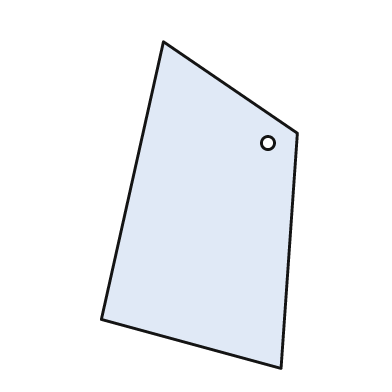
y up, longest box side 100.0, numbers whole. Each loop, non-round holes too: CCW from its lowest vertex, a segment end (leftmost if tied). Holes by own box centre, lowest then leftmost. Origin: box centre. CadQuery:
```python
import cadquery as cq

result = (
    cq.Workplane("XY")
    .moveTo(25.0, -50.0)
    .lineTo(30.0, 22.0)
    .lineTo(-11.0, 50.0)
    .lineTo(-30.0, -35.0)
    .close()
    .moveTo(21.0, 19.0)
    .circle(2.0)
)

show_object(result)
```